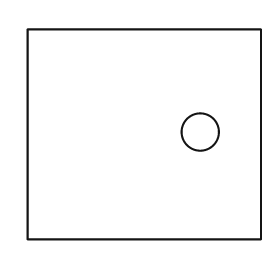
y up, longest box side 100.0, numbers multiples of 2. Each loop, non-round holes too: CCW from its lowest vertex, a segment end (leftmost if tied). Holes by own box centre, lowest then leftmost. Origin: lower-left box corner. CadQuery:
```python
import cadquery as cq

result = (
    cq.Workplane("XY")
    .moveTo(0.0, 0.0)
    .lineTo(100.0, 0.0)
    .lineTo(100.0, 90.0)
    .lineTo(0.0, 90.0)
    .close()
    .moveTo(74.0, 46.0)
    .circle(8.0)
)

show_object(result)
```